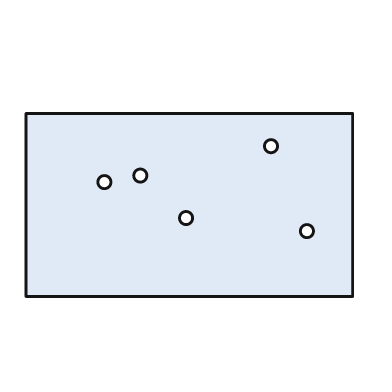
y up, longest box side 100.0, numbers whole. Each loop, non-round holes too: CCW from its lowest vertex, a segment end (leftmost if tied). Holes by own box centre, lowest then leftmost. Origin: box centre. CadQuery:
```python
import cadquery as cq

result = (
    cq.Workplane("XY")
    .moveTo(-50.0, -28.0)
    .lineTo(50.0, -28.0)
    .lineTo(50.0, 28.0)
    .lineTo(-50.0, 28.0)
    .close()
    .moveTo(36.0, -8.0)
    .circle(2.0)
    .moveTo(-1.0, -4.0)
    .circle(2.0)
    .moveTo(-26.0, 7.0)
    .circle(2.0)
    .moveTo(-15.0, 9.0)
    .circle(2.0)
    .moveTo(25.0, 18.0)
    .circle(2.0)
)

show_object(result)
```